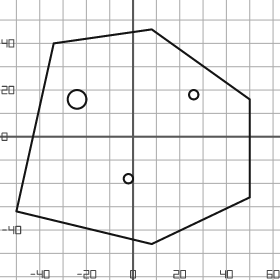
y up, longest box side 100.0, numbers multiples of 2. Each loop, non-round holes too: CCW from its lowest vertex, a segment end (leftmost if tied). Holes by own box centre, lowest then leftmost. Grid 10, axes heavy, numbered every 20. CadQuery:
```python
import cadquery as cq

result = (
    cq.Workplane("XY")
    .moveTo(8.0, -46.0)
    .lineTo(50.0, -26.0)
    .lineTo(50.0, 16.0)
    .lineTo(8.0, 46.0)
    .lineTo(-34.0, 40.0)
    .lineTo(-50.0, -32.0)
    .close()
    .moveTo(-2.0, -18.0)
    .circle(2.0)
    .moveTo(-24.0, 16.0)
    .circle(4.0)
    .moveTo(26.0, 18.0)
    .circle(2.0)
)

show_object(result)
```